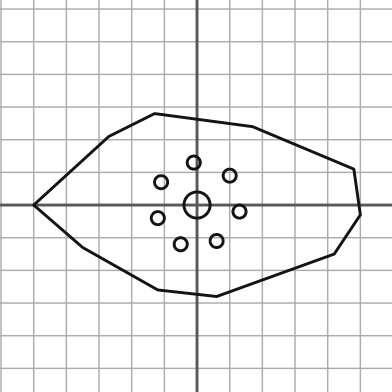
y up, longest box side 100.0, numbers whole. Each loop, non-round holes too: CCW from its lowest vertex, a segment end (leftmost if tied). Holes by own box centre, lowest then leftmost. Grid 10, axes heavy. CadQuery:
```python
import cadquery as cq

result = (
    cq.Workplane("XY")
    .moveTo(6.0, -28.0)
    .lineTo(42.0, -15.0)
    .lineTo(50.0, -3.0)
    .lineTo(48.0, 11.0)
    .lineTo(17.0, 24.0)
    .lineTo(-13.0, 28.0)
    .lineTo(-27.0, 21.0)
    .lineTo(-50.0, 0.0)
    .lineTo(-35.0, -13.0)
    .lineTo(-12.0, -26.0)
    .close()
    .moveTo(-5.0, -12.0)
    .circle(2.0)
    .moveTo(6.0, -11.0)
    .circle(2.0)
    .moveTo(-12.0, -4.0)
    .circle(2.0)
    .moveTo(13.0, -2.0)
    .circle(2.0)
    .moveTo(0.0, 0.0)
    .circle(4.0)
    .moveTo(-11.0, 7.0)
    .circle(2.0)
    .moveTo(10.0, 9.0)
    .circle(2.0)
    .moveTo(-1.0, 13.0)
    .circle(2.0)
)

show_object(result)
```